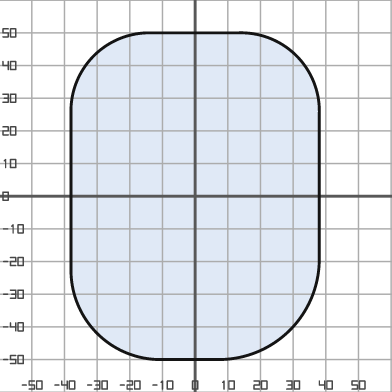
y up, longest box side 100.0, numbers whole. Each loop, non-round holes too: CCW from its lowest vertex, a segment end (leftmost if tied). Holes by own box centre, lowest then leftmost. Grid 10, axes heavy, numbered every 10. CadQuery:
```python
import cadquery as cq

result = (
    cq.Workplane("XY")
    .moveTo(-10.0, -50.0)
    .lineTo(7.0, -50.0)
    .threePointArc((29.0, -41.0), (38.0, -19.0))
    .lineTo(38.0, 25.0)
    .threePointArc((31.0, 43.0), (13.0, 50.0))
    .lineTo(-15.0, 50.0)
    .threePointArc((-31.0, 43.0), (-38.0, 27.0))
    .lineTo(-38.0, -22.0)
    .threePointArc((-30.0, -42.0), (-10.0, -50.0))
    .close()
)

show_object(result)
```